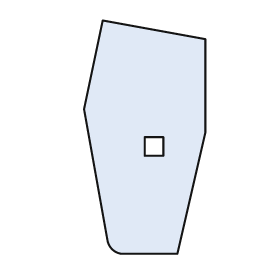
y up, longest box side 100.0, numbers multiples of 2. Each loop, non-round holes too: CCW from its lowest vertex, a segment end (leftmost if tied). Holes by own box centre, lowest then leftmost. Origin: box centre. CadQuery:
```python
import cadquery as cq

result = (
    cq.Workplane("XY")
    .moveTo(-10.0, -50.0)
    .lineTo(14.0, -50.0)
    .lineTo(26.0, 2.0)
    .lineTo(26.0, 42.0)
    .lineTo(-18.0, 50.0)
    .lineTo(-26.0, 12.0)
    .lineTo(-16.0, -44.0)
    .threePointArc((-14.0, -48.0), (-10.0, -50.0))
    .close()
    .moveTo(0.0, -8.0)
    .lineTo(8.0, -8.0)
    .lineTo(8.0, 0.0)
    .lineTo(0.0, 0.0)
    .close()
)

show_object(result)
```